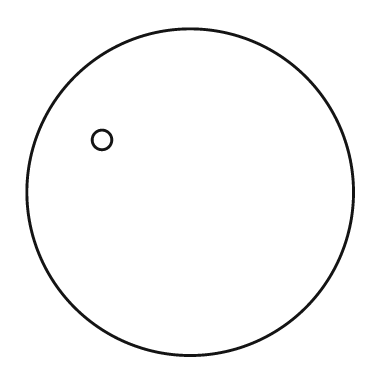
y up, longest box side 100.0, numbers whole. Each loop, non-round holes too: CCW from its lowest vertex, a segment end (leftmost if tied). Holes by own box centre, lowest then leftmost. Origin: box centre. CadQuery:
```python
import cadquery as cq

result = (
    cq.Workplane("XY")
    .moveTo(0.0, 0.0)
    .circle(50.0)
    .moveTo(-27.0, 16.0)
    .circle(3.0)
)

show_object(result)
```